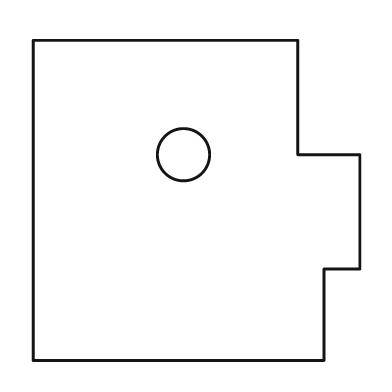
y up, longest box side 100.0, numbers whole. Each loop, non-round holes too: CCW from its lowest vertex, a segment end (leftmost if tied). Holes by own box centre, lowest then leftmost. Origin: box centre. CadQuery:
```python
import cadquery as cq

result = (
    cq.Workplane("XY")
    .moveTo(-50.0, -49.0)
    .lineTo(39.0, -49.0)
    .lineTo(39.0, -21.0)
    .lineTo(50.0, -21.0)
    .lineTo(50.0, 14.0)
    .lineTo(31.0, 14.0)
    .lineTo(31.0, 49.0)
    .lineTo(-50.0, 49.0)
    .close()
    .moveTo(-4.0, 14.0)
    .circle(8.0)
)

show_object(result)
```